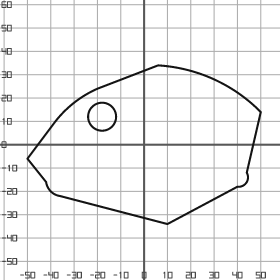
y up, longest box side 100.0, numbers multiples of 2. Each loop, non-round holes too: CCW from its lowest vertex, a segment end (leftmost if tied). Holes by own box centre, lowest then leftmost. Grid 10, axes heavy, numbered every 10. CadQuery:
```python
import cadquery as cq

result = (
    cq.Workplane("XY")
    .moveTo(10.0, -34.0)
    .lineTo(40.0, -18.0)
    .threePointArc((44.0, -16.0), (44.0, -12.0))
    .lineTo(50.0, 14.0)
    .threePointArc((30.0, 28.0), (6.0, 34.0))
    .lineTo(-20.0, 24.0)
    .threePointArc((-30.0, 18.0), (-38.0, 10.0))
    .lineTo(-50.0, -6.0)
    .lineTo(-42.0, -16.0)
    .threePointArc((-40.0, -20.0), (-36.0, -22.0))
    .close()
    .moveTo(-18.0, 12.0)
    .circle(6.0)
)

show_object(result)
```